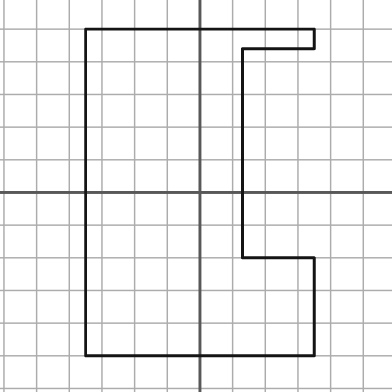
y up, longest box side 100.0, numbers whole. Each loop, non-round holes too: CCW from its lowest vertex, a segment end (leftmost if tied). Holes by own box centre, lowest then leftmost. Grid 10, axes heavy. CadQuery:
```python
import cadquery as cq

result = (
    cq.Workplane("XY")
    .moveTo(-35.0, -50.0)
    .lineTo(35.0, -50.0)
    .lineTo(35.0, -20.0)
    .lineTo(13.0, -20.0)
    .lineTo(13.0, 44.0)
    .lineTo(35.0, 44.0)
    .lineTo(35.0, 50.0)
    .lineTo(-35.0, 50.0)
    .close()
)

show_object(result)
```